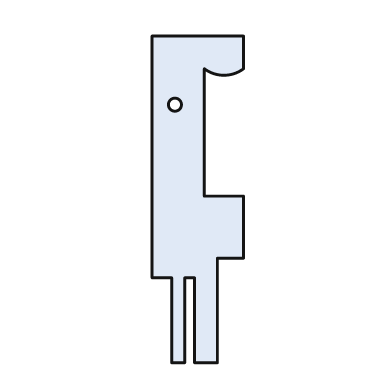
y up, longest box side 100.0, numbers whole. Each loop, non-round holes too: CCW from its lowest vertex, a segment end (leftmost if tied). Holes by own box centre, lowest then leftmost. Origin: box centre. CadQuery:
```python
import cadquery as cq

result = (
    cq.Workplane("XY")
    .moveTo(-8.0, -50.0)
    .lineTo(-4.0, -50.0)
    .lineTo(-4.0, -24.0)
    .lineTo(-1.0, -24.0)
    .lineTo(-1.0, -50.0)
    .lineTo(6.0, -50.0)
    .lineTo(6.0, -18.0)
    .lineTo(14.0, -18.0)
    .lineTo(14.0, 1.0)
    .lineTo(2.0, 1.0)
    .lineTo(2.0, 40.0)
    .threePointArc((8.0, 38.0), (14.0, 40.0))
    .lineTo(14.0, 50.0)
    .lineTo(-14.0, 50.0)
    .lineTo(-14.0, -24.0)
    .lineTo(-8.0, -24.0)
    .close()
    .moveTo(-7.0, 29.0)
    .circle(2.0)
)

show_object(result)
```